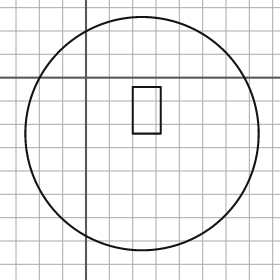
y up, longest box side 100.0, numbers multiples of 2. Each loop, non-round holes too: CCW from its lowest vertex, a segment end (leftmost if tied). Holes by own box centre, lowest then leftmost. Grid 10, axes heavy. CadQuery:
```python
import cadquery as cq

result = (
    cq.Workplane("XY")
    .moveTo(24.0, -24.0)
    .circle(50.0)
    .moveTo(20.0, -24.0)
    .lineTo(32.0, -24.0)
    .lineTo(32.0, -4.0)
    .lineTo(20.0, -4.0)
    .close()
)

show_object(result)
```